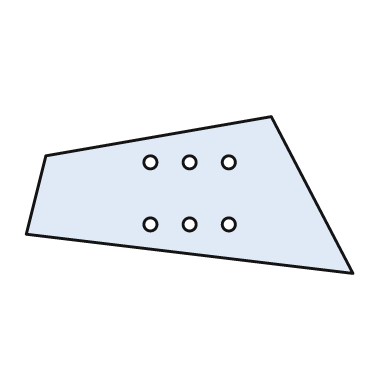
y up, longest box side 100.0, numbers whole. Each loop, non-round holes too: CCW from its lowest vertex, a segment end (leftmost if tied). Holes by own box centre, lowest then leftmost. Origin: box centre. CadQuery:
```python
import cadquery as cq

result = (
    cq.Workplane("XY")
    .moveTo(50.0, -24.0)
    .lineTo(25.0, 24.0)
    .lineTo(-44.0, 12.0)
    .lineTo(-50.0, -12.0)
    .close()
    .moveTo(-12.0, -9.0)
    .circle(2.0)
    .moveTo(0.0, -9.0)
    .circle(2.0)
    .moveTo(12.0, -9.0)
    .circle(2.0)
    .moveTo(-12.0, 10.0)
    .circle(2.0)
    .moveTo(0.0, 10.0)
    .circle(2.0)
    .moveTo(12.0, 10.0)
    .circle(2.0)
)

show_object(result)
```